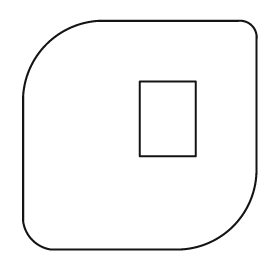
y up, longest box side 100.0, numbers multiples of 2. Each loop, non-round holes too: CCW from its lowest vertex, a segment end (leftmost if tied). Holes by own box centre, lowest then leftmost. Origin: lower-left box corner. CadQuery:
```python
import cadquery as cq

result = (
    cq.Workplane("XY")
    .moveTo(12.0, 0.0)
    .lineTo(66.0, 0.0)
    .threePointArc((90.0, 10.0), (100.0, 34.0))
    .lineTo(100.0, 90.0)
    .threePointArc((98.0, 96.0), (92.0, 98.0))
    .lineTo(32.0, 98.0)
    .threePointArc((10.0, 88.0), (0.0, 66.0))
    .lineTo(0.0, 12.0)
    .threePointArc((4.0, 4.0), (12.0, 0.0))
    .close()
    .moveTo(50.0, 40.0)
    .lineTo(74.0, 40.0)
    .lineTo(74.0, 72.0)
    .lineTo(50.0, 72.0)
    .close()
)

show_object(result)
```